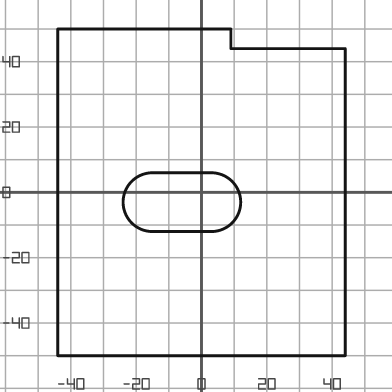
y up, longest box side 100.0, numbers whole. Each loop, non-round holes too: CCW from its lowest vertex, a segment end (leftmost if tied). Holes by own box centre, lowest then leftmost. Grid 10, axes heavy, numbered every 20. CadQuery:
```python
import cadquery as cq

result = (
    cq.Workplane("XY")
    .moveTo(-44.0, -50.0)
    .lineTo(44.0, -50.0)
    .lineTo(44.0, 44.0)
    .lineTo(9.0, 44.0)
    .lineTo(9.0, 50.0)
    .lineTo(-44.0, 50.0)
    .close()
    .moveTo(-15.0, -12.0)
    .lineTo(3.0, -12.0)
    .threePointArc((12.0, -3.0), (3.0, 6.0))
    .lineTo(-15.0, 6.0)
    .threePointArc((-24.0, -3.0), (-15.0, -12.0))
    .close()
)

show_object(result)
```